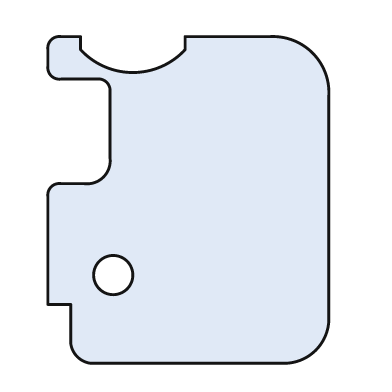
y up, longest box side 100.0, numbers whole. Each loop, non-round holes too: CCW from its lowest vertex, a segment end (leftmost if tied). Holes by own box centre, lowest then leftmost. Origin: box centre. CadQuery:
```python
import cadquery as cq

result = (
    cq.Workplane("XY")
    .moveTo(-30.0, -50.0)
    .lineTo(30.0, -50.0)
    .threePointArc((39.0, -46.0), (43.0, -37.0))
    .lineTo(43.0, 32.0)
    .threePointArc((38.0, 45.0), (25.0, 50.0))
    .lineTo(-1.0, 50.0)
    .lineTo(-1.0, 46.0)
    .threePointArc((-17.0, 39.0), (-33.0, 46.0))
    .lineTo(-33.0, 50.0)
    .lineTo(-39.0, 50.0)
    .threePointArc((-42.0, 49.0), (-43.0, 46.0))
    .lineTo(-43.0, 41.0)
    .threePointArc((-42.0, 38.0), (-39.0, 37.0))
    .lineTo(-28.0, 37.0)
    .threePointArc((-25.0, 36.0), (-24.0, 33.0))
    .lineTo(-24.0, 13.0)
    .threePointArc((-26.0, 7.0), (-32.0, 5.0))
    .lineTo(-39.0, 5.0)
    .threePointArc((-42.0, 4.0), (-43.0, 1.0))
    .lineTo(-43.0, -32.0)
    .lineTo(-36.0, -32.0)
    .lineTo(-36.0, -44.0)
    .threePointArc((-34.0, -48.0), (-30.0, -50.0))
    .close()
    .moveTo(-23.0, -23.0)
    .circle(6.0)
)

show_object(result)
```